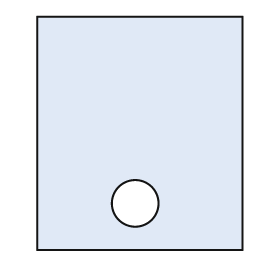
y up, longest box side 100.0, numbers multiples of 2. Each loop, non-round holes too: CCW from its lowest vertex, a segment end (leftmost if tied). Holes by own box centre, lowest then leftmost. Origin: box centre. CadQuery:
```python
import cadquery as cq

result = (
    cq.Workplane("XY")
    .moveTo(-44.0, -50.0)
    .lineTo(44.0, -50.0)
    .lineTo(44.0, 50.0)
    .lineTo(-44.0, 50.0)
    .close()
    .moveTo(-2.0, -30.0)
    .circle(10.0)
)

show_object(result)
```